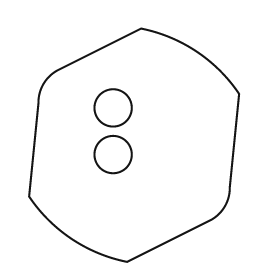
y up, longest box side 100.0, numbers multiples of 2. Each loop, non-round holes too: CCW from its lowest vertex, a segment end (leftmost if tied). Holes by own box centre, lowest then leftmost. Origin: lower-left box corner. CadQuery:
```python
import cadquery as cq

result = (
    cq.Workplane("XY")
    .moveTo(42.0, 0.0)
    .lineTo(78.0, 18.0)
    .threePointArc((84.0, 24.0), (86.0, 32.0))
    .lineTo(90.0, 72.0)
    .threePointArc((72.0, 90.0), (48.0, 100.0))
    .lineTo(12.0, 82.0)
    .threePointArc((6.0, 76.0), (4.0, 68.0))
    .lineTo(0.0, 28.0)
    .threePointArc((18.0, 10.0), (42.0, 0.0))
    .close()
    .moveTo(36.0, 46.0)
    .circle(8.0)
    .moveTo(36.0, 66.0)
    .circle(8.0)
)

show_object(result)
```